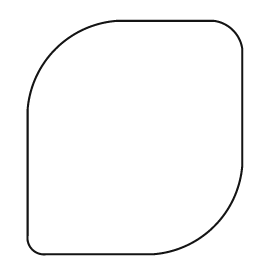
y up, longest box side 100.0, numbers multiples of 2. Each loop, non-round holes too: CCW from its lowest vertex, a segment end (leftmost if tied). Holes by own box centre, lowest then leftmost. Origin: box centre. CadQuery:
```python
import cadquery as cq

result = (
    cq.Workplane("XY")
    .moveTo(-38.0, -50.0)
    .lineTo(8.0, -50.0)
    .threePointArc((34.0, -38.0), (46.0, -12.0))
    .lineTo(46.0, 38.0)
    .threePointArc((42.0, 46.0), (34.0, 50.0))
    .lineTo(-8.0, 50.0)
    .threePointArc((-34.0, 38.0), (-46.0, 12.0))
    .lineTo(-46.0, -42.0)
    .threePointArc((-44.0, -48.0), (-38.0, -50.0))
    .close()
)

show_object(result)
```